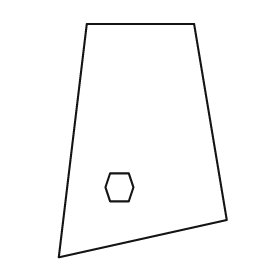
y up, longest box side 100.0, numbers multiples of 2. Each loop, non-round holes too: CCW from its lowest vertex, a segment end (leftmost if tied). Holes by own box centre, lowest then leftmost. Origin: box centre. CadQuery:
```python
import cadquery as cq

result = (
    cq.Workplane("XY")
    .moveTo(-36.0, -50.0)
    .lineTo(36.0, -34.0)
    .lineTo(22.0, 50.0)
    .lineTo(-24.0, 50.0)
    .close()
    .moveTo(-14.0, -26.0)
    .lineTo(-6.0, -26.0)
    .lineTo(-4.0, -20.0)
    .lineTo(-6.0, -14.0)
    .lineTo(-14.0, -14.0)
    .lineTo(-16.0, -20.0)
    .close()
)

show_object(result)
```